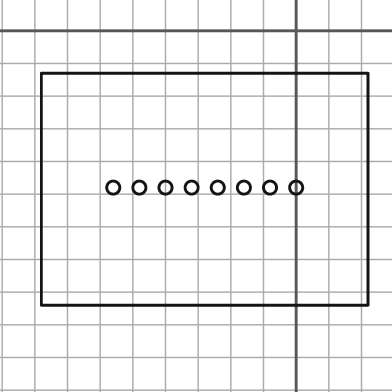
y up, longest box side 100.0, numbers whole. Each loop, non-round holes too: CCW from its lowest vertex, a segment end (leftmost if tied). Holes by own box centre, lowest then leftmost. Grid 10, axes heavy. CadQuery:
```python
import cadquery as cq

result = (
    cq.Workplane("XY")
    .moveTo(-78.0, -84.0)
    .lineTo(22.0, -84.0)
    .lineTo(22.0, -13.0)
    .lineTo(-78.0, -13.0)
    .close()
    .moveTo(-56.0, -48.0)
    .circle(2.0)
    .moveTo(-48.0, -48.0)
    .circle(2.0)
    .moveTo(-40.0, -48.0)
    .circle(2.0)
    .moveTo(-32.0, -48.0)
    .circle(2.0)
    .moveTo(-24.0, -48.0)
    .circle(2.0)
    .moveTo(-16.0, -48.0)
    .circle(2.0)
    .moveTo(-8.0, -48.0)
    .circle(2.0)
    .moveTo(0.0, -48.0)
    .circle(2.0)
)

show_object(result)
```